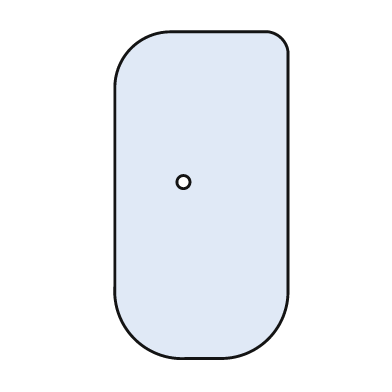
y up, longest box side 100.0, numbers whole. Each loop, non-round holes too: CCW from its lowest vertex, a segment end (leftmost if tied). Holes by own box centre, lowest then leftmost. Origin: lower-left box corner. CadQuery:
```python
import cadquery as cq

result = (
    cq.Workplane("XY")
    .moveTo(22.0, 0.0)
    .lineTo(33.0, 0.0)
    .threePointArc((47.0, 6.0), (53.0, 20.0))
    .lineTo(53.0, 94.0)
    .threePointArc((51.0, 98.0), (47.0, 100.0))
    .lineTo(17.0, 100.0)
    .threePointArc((5.0, 95.0), (0.0, 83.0))
    .lineTo(0.0, 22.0)
    .threePointArc((6.0, 6.0), (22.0, 0.0))
    .close()
    .moveTo(21.0, 54.0)
    .circle(2.0)
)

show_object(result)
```